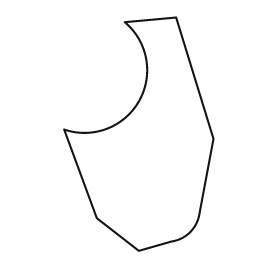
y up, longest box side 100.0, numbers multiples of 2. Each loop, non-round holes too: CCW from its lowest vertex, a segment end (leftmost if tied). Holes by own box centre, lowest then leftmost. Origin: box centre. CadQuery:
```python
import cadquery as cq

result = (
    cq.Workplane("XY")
    .moveTo(0.0, -50.0)
    .lineTo(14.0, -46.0)
    .threePointArc((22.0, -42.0), (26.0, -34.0))
    .lineTo(32.0, -2.0)
    .lineTo(16.0, 50.0)
    .lineTo(-6.0, 48.0)
    .threePointArc((0.0, 14.0), (-32.0, 2.0))
    .lineTo(-18.0, -36.0)
    .close()
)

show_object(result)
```